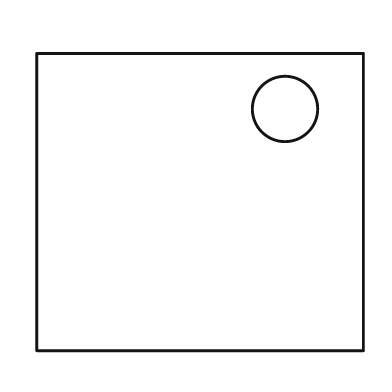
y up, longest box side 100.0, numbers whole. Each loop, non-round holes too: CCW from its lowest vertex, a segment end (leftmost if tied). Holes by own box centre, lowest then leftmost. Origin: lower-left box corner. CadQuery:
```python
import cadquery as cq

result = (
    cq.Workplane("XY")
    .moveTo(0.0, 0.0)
    .lineTo(100.0, 0.0)
    .lineTo(100.0, 91.0)
    .lineTo(0.0, 91.0)
    .close()
    .moveTo(76.0, 74.0)
    .circle(10.0)
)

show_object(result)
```